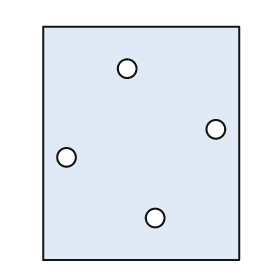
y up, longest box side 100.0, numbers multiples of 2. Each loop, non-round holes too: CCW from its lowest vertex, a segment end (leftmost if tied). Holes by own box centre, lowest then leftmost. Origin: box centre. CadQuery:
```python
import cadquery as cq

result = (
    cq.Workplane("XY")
    .moveTo(-42.0, -50.0)
    .lineTo(42.0, -50.0)
    .lineTo(42.0, 50.0)
    .lineTo(-42.0, 50.0)
    .close()
    .moveTo(6.0, -32.0)
    .circle(4.0)
    .moveTo(-32.0, -6.0)
    .circle(4.0)
    .moveTo(32.0, 6.0)
    .circle(4.0)
    .moveTo(-6.0, 32.0)
    .circle(4.0)
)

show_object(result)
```